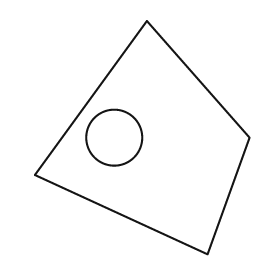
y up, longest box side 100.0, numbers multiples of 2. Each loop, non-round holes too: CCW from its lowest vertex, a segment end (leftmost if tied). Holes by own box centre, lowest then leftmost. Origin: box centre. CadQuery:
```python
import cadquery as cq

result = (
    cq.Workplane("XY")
    .moveTo(28.0, -50.0)
    .lineTo(46.0, 0.0)
    .lineTo(2.0, 50.0)
    .lineTo(-46.0, -16.0)
    .close()
    .moveTo(-12.0, 0.0)
    .circle(12.0)
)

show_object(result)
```